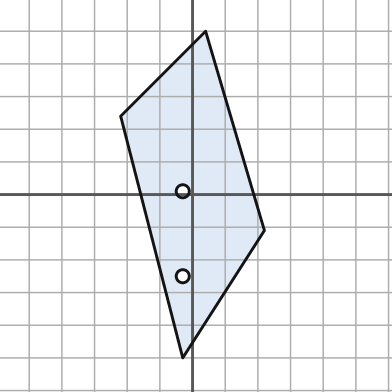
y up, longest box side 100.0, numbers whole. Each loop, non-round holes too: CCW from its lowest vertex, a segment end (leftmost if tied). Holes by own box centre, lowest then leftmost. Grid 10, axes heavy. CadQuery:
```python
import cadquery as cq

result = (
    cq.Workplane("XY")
    .moveTo(-3.0, -50.0)
    .lineTo(22.0, -11.0)
    .lineTo(4.0, 50.0)
    .lineTo(-22.0, 24.0)
    .close()
    .moveTo(-3.0, -25.0)
    .circle(2.0)
    .moveTo(-3.0, 1.0)
    .circle(2.0)
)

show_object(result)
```